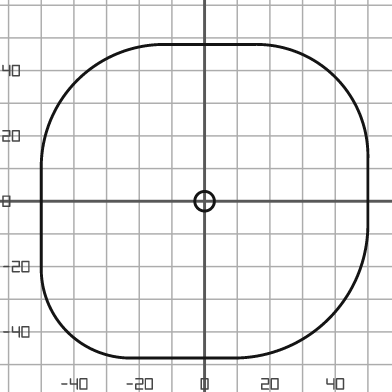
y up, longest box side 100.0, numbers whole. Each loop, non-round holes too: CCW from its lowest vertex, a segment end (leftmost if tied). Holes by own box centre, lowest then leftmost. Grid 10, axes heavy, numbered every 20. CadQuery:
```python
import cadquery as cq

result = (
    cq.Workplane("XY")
    .moveTo(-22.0, -48.0)
    .lineTo(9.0, -48.0)
    .threePointArc((38.0, -36.0), (50.0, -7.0))
    .lineTo(50.0, 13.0)
    .threePointArc((40.0, 38.0), (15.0, 48.0))
    .lineTo(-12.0, 48.0)
    .threePointArc((-39.0, 37.0), (-50.0, 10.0))
    .lineTo(-50.0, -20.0)
    .threePointArc((-42.0, -40.0), (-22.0, -48.0))
    .close()
    .moveTo(0.0, 0.0)
    .circle(3.0)
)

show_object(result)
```